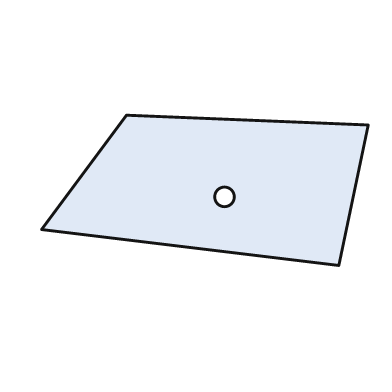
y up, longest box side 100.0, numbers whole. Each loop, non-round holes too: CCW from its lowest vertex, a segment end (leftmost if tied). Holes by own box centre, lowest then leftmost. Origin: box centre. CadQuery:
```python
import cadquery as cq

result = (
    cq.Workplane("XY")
    .moveTo(41.0, -23.0)
    .lineTo(50.0, 20.0)
    .lineTo(-24.0, 23.0)
    .lineTo(-50.0, -12.0)
    .close()
    .moveTo(6.0, -2.0)
    .circle(3.0)
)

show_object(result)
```